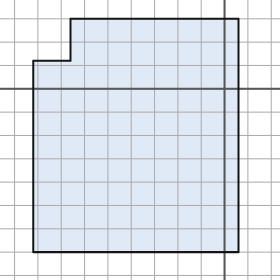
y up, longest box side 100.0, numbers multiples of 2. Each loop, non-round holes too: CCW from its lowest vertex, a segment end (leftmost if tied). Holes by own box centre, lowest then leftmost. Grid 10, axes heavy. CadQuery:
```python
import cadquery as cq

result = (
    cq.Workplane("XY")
    .moveTo(-82.0, -70.0)
    .lineTo(6.0, -70.0)
    .lineTo(6.0, 30.0)
    .lineTo(-66.0, 30.0)
    .lineTo(-66.0, 12.0)
    .lineTo(-82.0, 12.0)
    .close()
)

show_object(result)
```